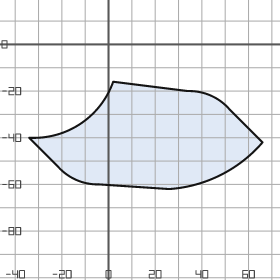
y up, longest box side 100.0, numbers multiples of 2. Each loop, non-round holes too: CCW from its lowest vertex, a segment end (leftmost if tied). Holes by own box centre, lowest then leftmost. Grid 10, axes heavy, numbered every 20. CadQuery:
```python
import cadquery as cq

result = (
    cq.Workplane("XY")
    .moveTo(26.0, -62.0)
    .threePointArc((48.0, -56.0), (66.0, -42.0))
    .lineTo(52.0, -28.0)
    .threePointArc((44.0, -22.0), (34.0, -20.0))
    .lineTo(2.0, -16.0)
    .threePointArc((-12.0, -34.0), (-34.0, -40.0))
    .lineTo(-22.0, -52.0)
    .threePointArc((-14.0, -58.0), (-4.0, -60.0))
    .close()
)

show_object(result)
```